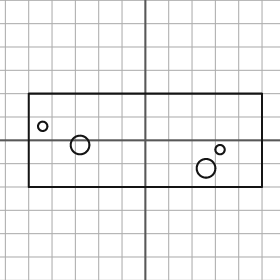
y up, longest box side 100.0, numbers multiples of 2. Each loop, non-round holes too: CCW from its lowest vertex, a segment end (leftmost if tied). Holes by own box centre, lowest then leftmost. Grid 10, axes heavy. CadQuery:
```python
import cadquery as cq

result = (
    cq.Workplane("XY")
    .moveTo(-50.0, -20.0)
    .lineTo(50.0, -20.0)
    .lineTo(50.0, 20.0)
    .lineTo(-50.0, 20.0)
    .close()
    .moveTo(26.0, -12.0)
    .circle(4.0)
    .moveTo(32.0, -4.0)
    .circle(2.0)
    .moveTo(-28.0, -2.0)
    .circle(4.0)
    .moveTo(-44.0, 6.0)
    .circle(2.0)
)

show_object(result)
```